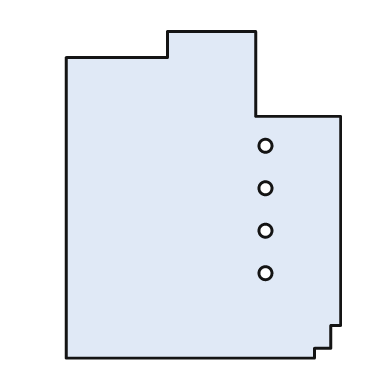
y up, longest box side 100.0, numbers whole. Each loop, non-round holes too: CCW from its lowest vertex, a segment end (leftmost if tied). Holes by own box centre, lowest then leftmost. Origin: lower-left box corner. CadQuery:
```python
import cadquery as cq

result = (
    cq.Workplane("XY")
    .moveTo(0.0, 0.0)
    .lineTo(76.0, 0.0)
    .lineTo(76.0, 3.0)
    .lineTo(81.0, 3.0)
    .lineTo(81.0, 10.0)
    .lineTo(84.0, 10.0)
    .lineTo(84.0, 74.0)
    .lineTo(58.0, 74.0)
    .lineTo(58.0, 100.0)
    .lineTo(31.0, 100.0)
    .lineTo(31.0, 92.0)
    .lineTo(0.0, 92.0)
    .close()
    .moveTo(61.0, 26.0)
    .circle(2.0)
    .moveTo(61.0, 39.0)
    .circle(2.0)
    .moveTo(61.0, 52.0)
    .circle(2.0)
    .moveTo(61.0, 65.0)
    .circle(2.0)
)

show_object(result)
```